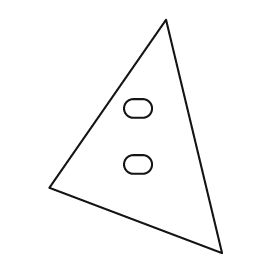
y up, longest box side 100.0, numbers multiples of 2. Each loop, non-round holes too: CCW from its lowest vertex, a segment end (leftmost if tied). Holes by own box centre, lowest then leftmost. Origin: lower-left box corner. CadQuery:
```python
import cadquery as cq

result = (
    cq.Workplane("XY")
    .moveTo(74.0, 0.0)
    .lineTo(50.0, 100.0)
    .lineTo(0.0, 28.0)
    .close()
    .moveTo(36.0, 34.0)
    .lineTo(40.0, 34.0)
    .threePointArc((44.0, 38.0), (40.0, 42.0))
    .lineTo(36.0, 42.0)
    .threePointArc((32.0, 38.0), (36.0, 34.0))
    .close()
    .moveTo(36.0, 58.0)
    .lineTo(40.0, 58.0)
    .threePointArc((44.0, 62.0), (40.0, 66.0))
    .lineTo(36.0, 66.0)
    .threePointArc((32.0, 62.0), (36.0, 58.0))
    .close()
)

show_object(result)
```